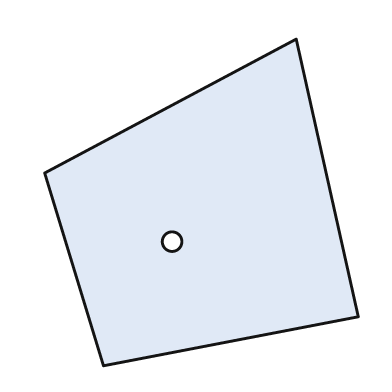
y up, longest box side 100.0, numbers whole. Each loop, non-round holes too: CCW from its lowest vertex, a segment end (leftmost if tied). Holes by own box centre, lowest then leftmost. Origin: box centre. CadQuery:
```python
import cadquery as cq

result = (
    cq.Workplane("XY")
    .moveTo(-30.0, -50.0)
    .lineTo(48.0, -35.0)
    .lineTo(29.0, 50.0)
    .lineTo(-48.0, 9.0)
    .close()
    .moveTo(-9.0, -12.0)
    .circle(3.0)
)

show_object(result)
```